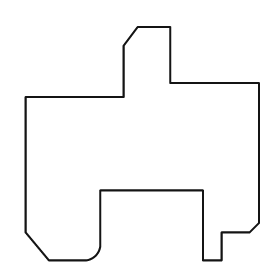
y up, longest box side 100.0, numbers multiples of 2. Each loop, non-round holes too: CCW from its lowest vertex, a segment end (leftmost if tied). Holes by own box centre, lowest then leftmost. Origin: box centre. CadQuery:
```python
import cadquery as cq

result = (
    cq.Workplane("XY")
    .moveTo(-40.0, -50.0)
    .lineTo(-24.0, -50.0)
    .threePointArc((-20.0, -48.0), (-18.0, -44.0))
    .lineTo(-18.0, -20.0)
    .lineTo(26.0, -20.0)
    .lineTo(26.0, -50.0)
    .lineTo(34.0, -50.0)
    .lineTo(34.0, -38.0)
    .lineTo(46.0, -38.0)
    .lineTo(50.0, -34.0)
    .lineTo(50.0, 26.0)
    .lineTo(12.0, 26.0)
    .lineTo(12.0, 50.0)
    .lineTo(-2.0, 50.0)
    .lineTo(-8.0, 42.0)
    .lineTo(-8.0, 20.0)
    .lineTo(-50.0, 20.0)
    .lineTo(-50.0, -38.0)
    .close()
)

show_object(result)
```